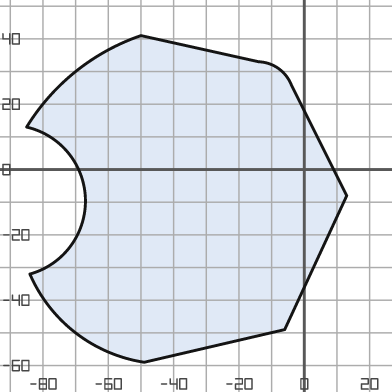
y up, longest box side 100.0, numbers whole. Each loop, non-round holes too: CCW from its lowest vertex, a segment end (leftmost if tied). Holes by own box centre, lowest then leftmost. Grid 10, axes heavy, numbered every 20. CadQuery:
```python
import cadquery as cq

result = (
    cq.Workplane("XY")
    .moveTo(-49.0, -59.0)
    .lineTo(-6.0, -49.0)
    .lineTo(13.0, -8.0)
    .lineTo(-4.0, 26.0)
    .threePointArc((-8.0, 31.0), (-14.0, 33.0))
    .lineTo(-50.0, 41.0)
    .threePointArc((-70.0, 30.0), (-85.0, 13.0))
    .threePointArc((-67.0, -9.0), (-84.0, -32.0))
    .threePointArc((-70.0, -50.0), (-49.0, -59.0))
    .close()
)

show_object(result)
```